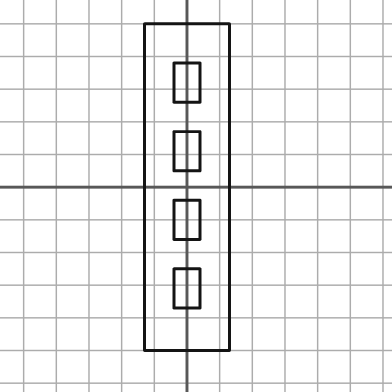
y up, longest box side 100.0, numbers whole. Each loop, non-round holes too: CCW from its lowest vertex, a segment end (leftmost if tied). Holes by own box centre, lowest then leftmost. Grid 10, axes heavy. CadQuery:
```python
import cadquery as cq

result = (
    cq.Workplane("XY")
    .moveTo(-13.0, -50.0)
    .lineTo(13.0, -50.0)
    .lineTo(13.0, 50.0)
    .lineTo(-13.0, 50.0)
    .close()
    .moveTo(-4.0, -37.0)
    .lineTo(4.0, -37.0)
    .lineTo(4.0, -25.0)
    .lineTo(-4.0, -25.0)
    .close()
    .moveTo(-4.0, -16.0)
    .lineTo(4.0, -16.0)
    .lineTo(4.0, -4.0)
    .lineTo(-4.0, -4.0)
    .close()
    .moveTo(-4.0, 5.0)
    .lineTo(4.0, 5.0)
    .lineTo(4.0, 17.0)
    .lineTo(-4.0, 17.0)
    .close()
    .moveTo(-4.0, 26.0)
    .lineTo(4.0, 26.0)
    .lineTo(4.0, 38.0)
    .lineTo(-4.0, 38.0)
    .close()
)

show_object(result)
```